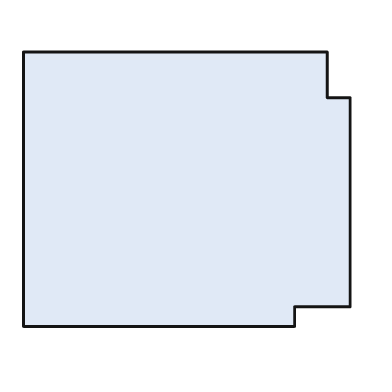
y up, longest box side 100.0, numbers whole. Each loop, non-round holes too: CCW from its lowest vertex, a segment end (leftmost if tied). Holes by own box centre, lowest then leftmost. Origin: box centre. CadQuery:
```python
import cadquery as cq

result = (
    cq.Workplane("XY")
    .moveTo(-50.0, -42.0)
    .lineTo(33.0, -42.0)
    .lineTo(33.0, -36.0)
    .lineTo(50.0, -36.0)
    .lineTo(50.0, 28.0)
    .lineTo(43.0, 28.0)
    .lineTo(43.0, 42.0)
    .lineTo(-50.0, 42.0)
    .close()
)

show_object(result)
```